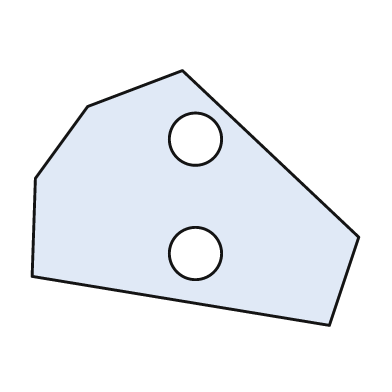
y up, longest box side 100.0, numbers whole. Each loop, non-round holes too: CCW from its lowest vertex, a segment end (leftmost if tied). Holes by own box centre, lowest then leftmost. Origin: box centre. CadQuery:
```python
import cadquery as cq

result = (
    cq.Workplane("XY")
    .moveTo(41.0, -39.0)
    .lineTo(50.0, -12.0)
    .lineTo(-4.0, 39.0)
    .lineTo(-33.0, 28.0)
    .lineTo(-49.0, 6.0)
    .lineTo(-50.0, -24.0)
    .close()
    .moveTo(0.0, -17.0)
    .circle(8.0)
    .moveTo(0.0, 18.0)
    .circle(8.0)
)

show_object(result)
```